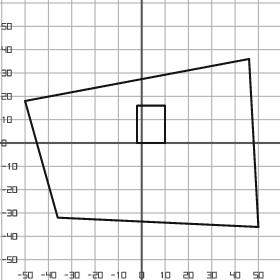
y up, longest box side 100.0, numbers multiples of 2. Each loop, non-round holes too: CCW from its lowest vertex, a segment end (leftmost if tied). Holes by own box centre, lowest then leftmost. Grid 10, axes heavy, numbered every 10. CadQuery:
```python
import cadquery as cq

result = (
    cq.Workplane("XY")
    .moveTo(50.0, -36.0)
    .lineTo(46.0, 36.0)
    .lineTo(-50.0, 18.0)
    .lineTo(-36.0, -32.0)
    .close()
    .moveTo(-2.0, 0.0)
    .lineTo(10.0, 0.0)
    .lineTo(10.0, 16.0)
    .lineTo(-2.0, 16.0)
    .close()
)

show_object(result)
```